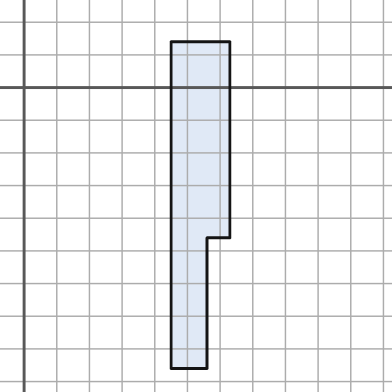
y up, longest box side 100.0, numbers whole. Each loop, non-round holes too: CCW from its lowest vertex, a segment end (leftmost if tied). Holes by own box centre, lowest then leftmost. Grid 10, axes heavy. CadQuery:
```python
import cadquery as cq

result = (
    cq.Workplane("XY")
    .moveTo(45.0, -86.0)
    .lineTo(56.0, -86.0)
    .lineTo(56.0, -46.0)
    .lineTo(63.0, -46.0)
    .lineTo(63.0, 14.0)
    .lineTo(45.0, 14.0)
    .close()
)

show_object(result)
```